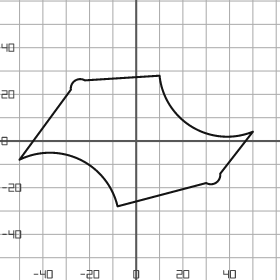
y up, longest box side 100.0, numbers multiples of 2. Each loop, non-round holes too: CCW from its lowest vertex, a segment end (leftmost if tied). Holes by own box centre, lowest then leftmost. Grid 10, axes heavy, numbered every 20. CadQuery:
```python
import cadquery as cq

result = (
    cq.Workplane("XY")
    .moveTo(-8.0, -28.0)
    .lineTo(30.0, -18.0)
    .threePointArc((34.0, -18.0), (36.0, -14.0))
    .lineTo(50.0, 4.0)
    .threePointArc((24.0, 6.0), (10.0, 28.0))
    .lineTo(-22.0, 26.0)
    .threePointArc((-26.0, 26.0), (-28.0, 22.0))
    .lineTo(-50.0, -8.0)
    .threePointArc((-24.0, -8.0), (-8.0, -28.0))
    .close()
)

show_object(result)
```